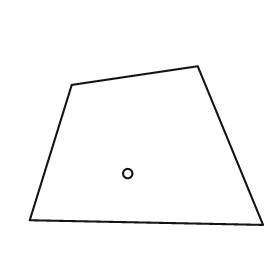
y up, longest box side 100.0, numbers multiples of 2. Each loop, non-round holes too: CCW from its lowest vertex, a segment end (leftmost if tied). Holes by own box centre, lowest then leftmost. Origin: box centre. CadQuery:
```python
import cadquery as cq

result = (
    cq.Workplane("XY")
    .moveTo(50.0, -34.0)
    .lineTo(22.0, 34.0)
    .lineTo(-32.0, 26.0)
    .lineTo(-50.0, -32.0)
    .close()
    .moveTo(-8.0, -12.0)
    .circle(2.0)
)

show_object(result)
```